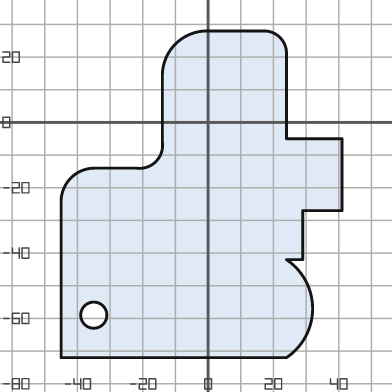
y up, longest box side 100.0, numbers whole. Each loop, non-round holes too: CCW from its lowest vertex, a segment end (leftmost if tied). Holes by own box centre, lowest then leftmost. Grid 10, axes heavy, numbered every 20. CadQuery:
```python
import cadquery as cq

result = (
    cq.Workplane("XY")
    .moveTo(-45.0, -72.0)
    .lineTo(24.0, -72.0)
    .threePointArc((32.0, -57.0), (24.0, -42.0))
    .lineTo(29.0, -42.0)
    .lineTo(29.0, -27.0)
    .lineTo(41.0, -27.0)
    .lineTo(41.0, -5.0)
    .lineTo(24.0, -5.0)
    .lineTo(24.0, 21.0)
    .threePointArc((22.0, 26.0), (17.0, 28.0))
    .lineTo(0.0, 28.0)
    .threePointArc((-10.0, 24.0), (-14.0, 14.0))
    .lineTo(-14.0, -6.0)
    .threePointArc((-16.0, -12.0), (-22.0, -14.0))
    .lineTo(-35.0, -14.0)
    .threePointArc((-42.0, -17.0), (-45.0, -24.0))
    .close()
    .moveTo(-35.0, -59.0)
    .circle(4.0)
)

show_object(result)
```